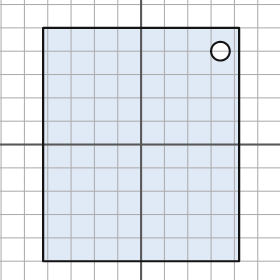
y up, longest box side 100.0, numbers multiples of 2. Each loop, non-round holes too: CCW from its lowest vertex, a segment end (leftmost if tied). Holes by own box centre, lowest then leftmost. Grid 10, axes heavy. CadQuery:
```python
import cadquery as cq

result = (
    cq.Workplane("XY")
    .moveTo(-42.0, -50.0)
    .lineTo(42.0, -50.0)
    .lineTo(42.0, 50.0)
    .lineTo(-42.0, 50.0)
    .close()
    .moveTo(34.0, 40.0)
    .circle(4.0)
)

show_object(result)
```